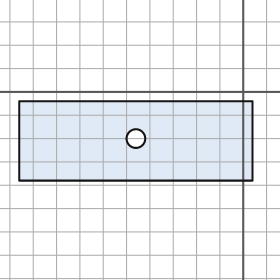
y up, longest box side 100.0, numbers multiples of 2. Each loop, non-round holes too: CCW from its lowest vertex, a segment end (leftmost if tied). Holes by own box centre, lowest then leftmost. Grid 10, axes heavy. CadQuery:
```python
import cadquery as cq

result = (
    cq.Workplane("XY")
    .moveTo(-96.0, -38.0)
    .lineTo(4.0, -38.0)
    .lineTo(4.0, -4.0)
    .lineTo(-96.0, -4.0)
    .close()
    .moveTo(-46.0, -20.0)
    .circle(4.0)
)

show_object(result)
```